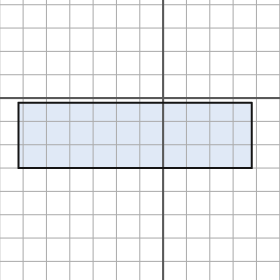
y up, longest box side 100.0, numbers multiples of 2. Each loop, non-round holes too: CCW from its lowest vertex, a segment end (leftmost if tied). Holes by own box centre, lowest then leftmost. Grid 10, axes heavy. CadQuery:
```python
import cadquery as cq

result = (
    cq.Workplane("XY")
    .moveTo(-62.0, -30.0)
    .lineTo(38.0, -30.0)
    .lineTo(38.0, -2.0)
    .lineTo(-62.0, -2.0)
    .close()
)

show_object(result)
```